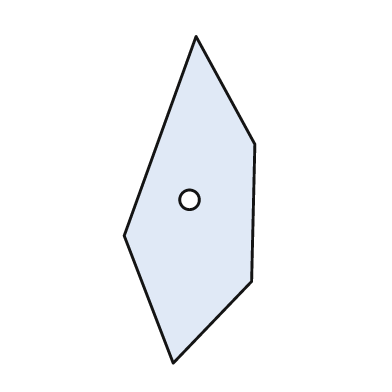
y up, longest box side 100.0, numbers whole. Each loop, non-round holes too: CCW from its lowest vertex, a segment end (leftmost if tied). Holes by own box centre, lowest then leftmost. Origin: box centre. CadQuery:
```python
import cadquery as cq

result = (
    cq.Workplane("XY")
    .moveTo(-5.0, -50.0)
    .lineTo(19.0, -25.0)
    .lineTo(20.0, 17.0)
    .lineTo(2.0, 50.0)
    .lineTo(-20.0, -11.0)
    .close()
    .moveTo(0.0, 0.0)
    .circle(3.0)
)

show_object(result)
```